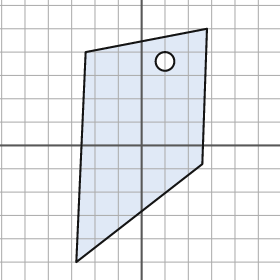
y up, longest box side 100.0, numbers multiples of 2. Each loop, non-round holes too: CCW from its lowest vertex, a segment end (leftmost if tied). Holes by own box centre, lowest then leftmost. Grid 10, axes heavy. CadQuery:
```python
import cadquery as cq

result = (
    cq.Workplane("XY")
    .moveTo(-28.0, -50.0)
    .lineTo(26.0, -8.0)
    .lineTo(28.0, 50.0)
    .lineTo(-24.0, 40.0)
    .close()
    .moveTo(10.0, 36.0)
    .circle(4.0)
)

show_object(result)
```